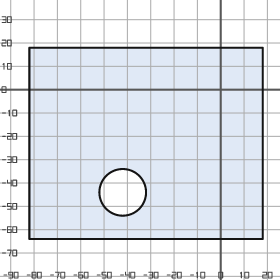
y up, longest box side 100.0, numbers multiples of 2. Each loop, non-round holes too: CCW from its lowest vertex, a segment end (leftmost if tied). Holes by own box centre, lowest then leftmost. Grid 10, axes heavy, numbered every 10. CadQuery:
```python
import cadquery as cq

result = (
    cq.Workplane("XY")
    .moveTo(-82.0, -64.0)
    .lineTo(18.0, -64.0)
    .lineTo(18.0, 18.0)
    .lineTo(-82.0, 18.0)
    .close()
    .moveTo(-42.0, -44.0)
    .circle(10.0)
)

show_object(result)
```